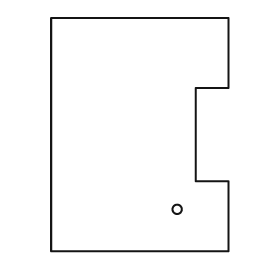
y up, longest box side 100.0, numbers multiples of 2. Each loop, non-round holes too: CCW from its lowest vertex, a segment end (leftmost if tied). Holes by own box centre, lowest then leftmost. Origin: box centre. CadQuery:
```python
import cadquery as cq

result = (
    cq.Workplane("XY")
    .moveTo(-38.0, -50.0)
    .lineTo(38.0, -50.0)
    .lineTo(38.0, -20.0)
    .lineTo(24.0, -20.0)
    .lineTo(24.0, 20.0)
    .lineTo(38.0, 20.0)
    .lineTo(38.0, 50.0)
    .lineTo(-38.0, 50.0)
    .close()
    .moveTo(16.0, -32.0)
    .circle(2.0)
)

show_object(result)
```